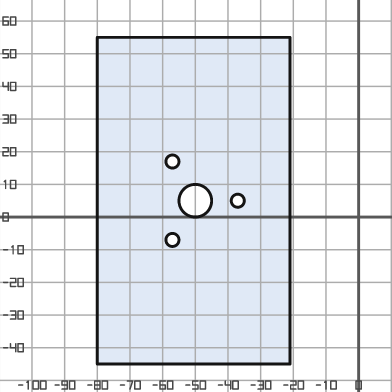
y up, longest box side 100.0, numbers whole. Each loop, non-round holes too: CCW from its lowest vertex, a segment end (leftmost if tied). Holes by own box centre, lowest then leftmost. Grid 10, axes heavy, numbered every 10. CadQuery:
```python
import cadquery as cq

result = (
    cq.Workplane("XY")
    .moveTo(-80.0, -45.0)
    .lineTo(-21.0, -45.0)
    .lineTo(-21.0, 55.0)
    .lineTo(-80.0, 55.0)
    .close()
    .moveTo(-57.0, -7.0)
    .circle(2.0)
    .moveTo(-50.0, 5.0)
    .circle(5.0)
    .moveTo(-37.0, 5.0)
    .circle(2.0)
    .moveTo(-57.0, 17.0)
    .circle(2.0)
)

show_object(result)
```